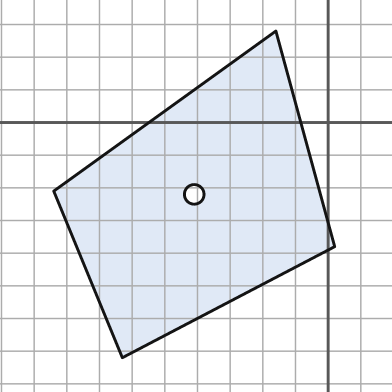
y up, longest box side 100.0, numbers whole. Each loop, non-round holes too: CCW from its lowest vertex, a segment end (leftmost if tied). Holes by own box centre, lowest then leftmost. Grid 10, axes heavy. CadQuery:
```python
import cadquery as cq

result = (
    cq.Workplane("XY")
    .moveTo(-63.0, -72.0)
    .lineTo(2.0, -38.0)
    .lineTo(-16.0, 28.0)
    .lineTo(-84.0, -21.0)
    .close()
    .moveTo(-41.0, -22.0)
    .circle(3.0)
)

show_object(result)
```